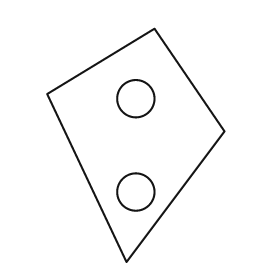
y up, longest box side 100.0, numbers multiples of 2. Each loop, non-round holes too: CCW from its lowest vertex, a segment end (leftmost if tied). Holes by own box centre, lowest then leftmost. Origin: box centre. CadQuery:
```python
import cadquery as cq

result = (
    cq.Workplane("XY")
    .moveTo(-4.0, -50.0)
    .lineTo(38.0, 6.0)
    .lineTo(8.0, 50.0)
    .lineTo(-38.0, 22.0)
    .close()
    .moveTo(0.0, -20.0)
    .circle(8.0)
    .moveTo(0.0, 20.0)
    .circle(8.0)
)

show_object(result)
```